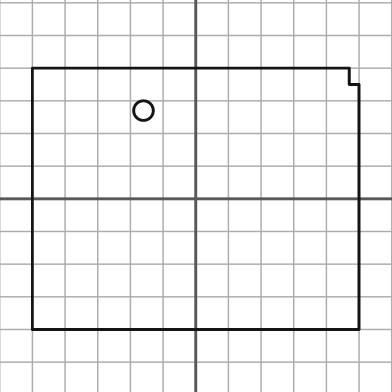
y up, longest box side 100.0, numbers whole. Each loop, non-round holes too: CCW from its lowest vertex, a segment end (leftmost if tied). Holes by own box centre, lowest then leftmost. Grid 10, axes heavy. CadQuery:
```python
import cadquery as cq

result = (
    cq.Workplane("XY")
    .moveTo(-50.0, -40.0)
    .lineTo(50.0, -40.0)
    .lineTo(50.0, 35.0)
    .lineTo(47.0, 35.0)
    .lineTo(47.0, 40.0)
    .lineTo(-50.0, 40.0)
    .close()
    .moveTo(-16.0, 27.0)
    .circle(3.0)
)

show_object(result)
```